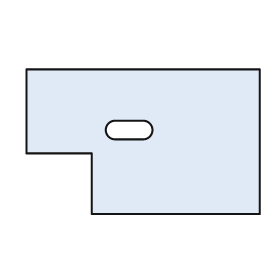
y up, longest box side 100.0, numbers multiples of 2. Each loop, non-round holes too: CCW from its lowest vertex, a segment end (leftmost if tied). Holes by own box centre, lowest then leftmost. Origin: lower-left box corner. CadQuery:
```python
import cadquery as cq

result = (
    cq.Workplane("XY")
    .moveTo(28.0, 0.0)
    .lineTo(100.0, 0.0)
    .lineTo(100.0, 62.0)
    .lineTo(0.0, 62.0)
    .lineTo(0.0, 26.0)
    .lineTo(28.0, 26.0)
    .close()
    .moveTo(38.0, 32.0)
    .lineTo(50.0, 32.0)
    .threePointArc((54.0, 36.0), (50.0, 40.0))
    .lineTo(38.0, 40.0)
    .threePointArc((34.0, 36.0), (38.0, 32.0))
    .close()
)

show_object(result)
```